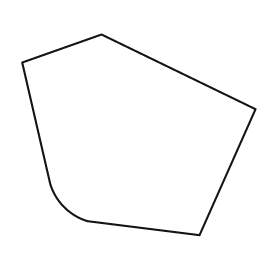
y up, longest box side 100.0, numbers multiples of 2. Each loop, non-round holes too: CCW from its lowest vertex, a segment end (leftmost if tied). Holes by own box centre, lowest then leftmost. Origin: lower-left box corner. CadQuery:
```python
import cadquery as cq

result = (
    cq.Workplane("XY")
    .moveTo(76.0, 0.0)
    .lineTo(100.0, 54.0)
    .lineTo(34.0, 86.0)
    .lineTo(0.0, 74.0)
    .lineTo(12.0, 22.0)
    .threePointArc((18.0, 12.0), (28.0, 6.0))
    .close()
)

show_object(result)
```